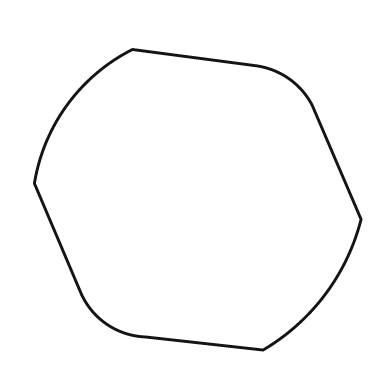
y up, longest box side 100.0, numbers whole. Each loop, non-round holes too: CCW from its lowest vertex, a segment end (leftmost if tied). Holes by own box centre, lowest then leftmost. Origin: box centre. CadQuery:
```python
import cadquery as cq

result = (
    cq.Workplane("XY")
    .moveTo(20.0, -46.0)
    .threePointArc((39.0, -29.0), (50.0, -6.0))
    .lineTo(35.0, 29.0)
    .threePointArc((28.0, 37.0), (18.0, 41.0))
    .lineTo(-20.0, 46.0)
    .threePointArc((-40.0, 29.0), (-50.0, 5.0))
    .lineTo(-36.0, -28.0)
    .threePointArc((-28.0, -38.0), (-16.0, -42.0))
    .close()
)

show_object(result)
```